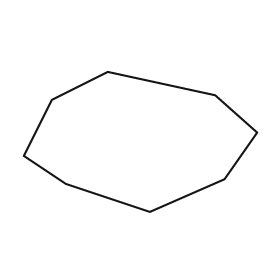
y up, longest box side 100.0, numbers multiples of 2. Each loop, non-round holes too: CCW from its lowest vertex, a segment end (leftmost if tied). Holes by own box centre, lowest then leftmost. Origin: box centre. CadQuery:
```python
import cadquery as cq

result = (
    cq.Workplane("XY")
    .moveTo(4.0, -30.0)
    .lineTo(36.0, -16.0)
    .lineTo(50.0, 4.0)
    .lineTo(32.0, 20.0)
    .lineTo(-14.0, 30.0)
    .lineTo(-38.0, 18.0)
    .lineTo(-50.0, -6.0)
    .lineTo(-32.0, -18.0)
    .close()
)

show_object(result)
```